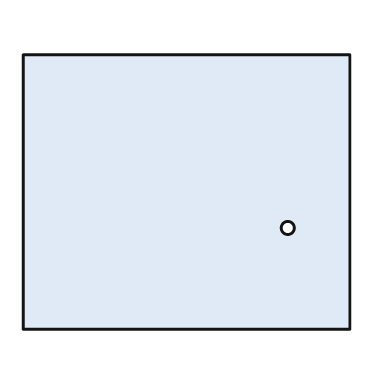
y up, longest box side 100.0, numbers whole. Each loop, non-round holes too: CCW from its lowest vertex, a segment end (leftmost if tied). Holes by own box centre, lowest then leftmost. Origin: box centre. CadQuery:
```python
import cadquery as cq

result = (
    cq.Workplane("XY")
    .moveTo(-50.0, -42.0)
    .lineTo(50.0, -42.0)
    .lineTo(50.0, 42.0)
    .lineTo(-50.0, 42.0)
    .close()
    .moveTo(31.0, -11.0)
    .circle(2.0)
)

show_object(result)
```